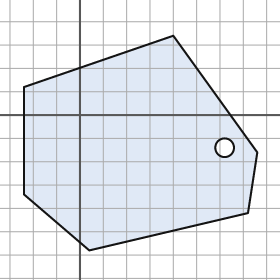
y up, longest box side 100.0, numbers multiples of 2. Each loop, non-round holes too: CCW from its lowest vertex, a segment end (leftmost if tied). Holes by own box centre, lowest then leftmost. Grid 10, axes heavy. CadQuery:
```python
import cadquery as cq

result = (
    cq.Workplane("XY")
    .moveTo(4.0, -58.0)
    .lineTo(72.0, -42.0)
    .lineTo(76.0, -16.0)
    .lineTo(40.0, 34.0)
    .lineTo(-24.0, 12.0)
    .lineTo(-24.0, -34.0)
    .close()
    .moveTo(62.0, -14.0)
    .circle(4.0)
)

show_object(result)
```